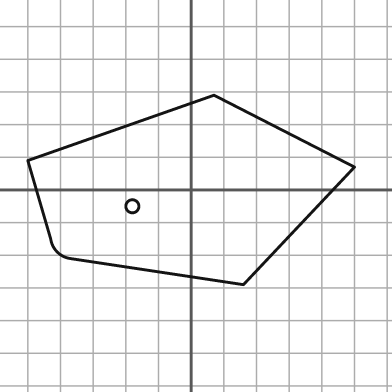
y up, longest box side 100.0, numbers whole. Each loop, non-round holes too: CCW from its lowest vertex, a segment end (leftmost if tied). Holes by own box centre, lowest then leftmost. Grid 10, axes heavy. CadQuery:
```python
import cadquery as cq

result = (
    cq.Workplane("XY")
    .moveTo(16.0, -29.0)
    .lineTo(50.0, 7.0)
    .lineTo(7.0, 29.0)
    .lineTo(-50.0, 9.0)
    .lineTo(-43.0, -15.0)
    .threePointArc((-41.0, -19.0), (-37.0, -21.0))
    .close()
    .moveTo(-18.0, -5.0)
    .circle(2.0)
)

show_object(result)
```